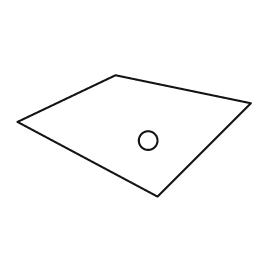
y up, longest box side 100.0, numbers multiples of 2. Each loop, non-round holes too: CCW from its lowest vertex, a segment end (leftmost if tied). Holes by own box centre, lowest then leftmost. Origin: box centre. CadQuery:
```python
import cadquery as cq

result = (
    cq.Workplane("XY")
    .moveTo(10.0, -26.0)
    .lineTo(50.0, 14.0)
    .lineTo(-8.0, 26.0)
    .lineTo(-50.0, 6.0)
    .close()
    .moveTo(6.0, -2.0)
    .circle(4.0)
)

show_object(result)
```